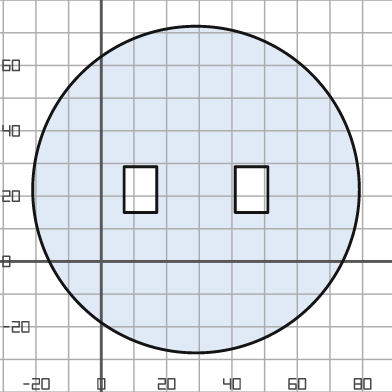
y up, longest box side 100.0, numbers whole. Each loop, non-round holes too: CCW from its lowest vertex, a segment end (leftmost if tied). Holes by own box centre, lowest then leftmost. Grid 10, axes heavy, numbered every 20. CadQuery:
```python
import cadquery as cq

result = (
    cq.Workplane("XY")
    .moveTo(29.0, 22.0)
    .circle(50.0)
    .moveTo(7.0, 15.0)
    .lineTo(17.0, 15.0)
    .lineTo(17.0, 29.0)
    .lineTo(7.0, 29.0)
    .close()
    .moveTo(41.0, 15.0)
    .lineTo(51.0, 15.0)
    .lineTo(51.0, 29.0)
    .lineTo(41.0, 29.0)
    .close()
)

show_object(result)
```